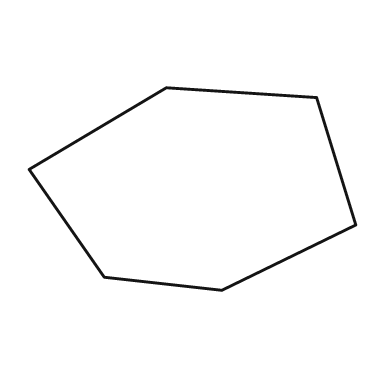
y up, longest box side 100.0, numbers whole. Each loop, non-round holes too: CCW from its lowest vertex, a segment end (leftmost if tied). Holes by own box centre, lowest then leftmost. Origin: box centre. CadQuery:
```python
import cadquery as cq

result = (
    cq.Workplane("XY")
    .moveTo(9.0, -31.0)
    .lineTo(50.0, -11.0)
    .lineTo(38.0, 28.0)
    .lineTo(-8.0, 31.0)
    .lineTo(-50.0, 6.0)
    .lineTo(-27.0, -27.0)
    .close()
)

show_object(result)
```